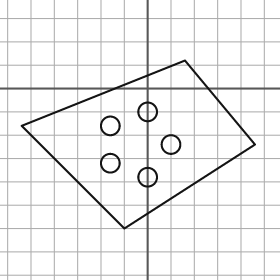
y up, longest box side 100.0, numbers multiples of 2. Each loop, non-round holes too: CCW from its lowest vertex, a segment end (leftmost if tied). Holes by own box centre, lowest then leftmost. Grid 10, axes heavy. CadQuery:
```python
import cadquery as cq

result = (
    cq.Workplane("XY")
    .moveTo(-10.0, -60.0)
    .lineTo(46.0, -24.0)
    .lineTo(16.0, 12.0)
    .lineTo(-54.0, -16.0)
    .close()
    .moveTo(0.0, -38.0)
    .circle(4.0)
    .moveTo(-16.0, -32.0)
    .circle(4.0)
    .moveTo(10.0, -24.0)
    .circle(4.0)
    .moveTo(-16.0, -16.0)
    .circle(4.0)
    .moveTo(0.0, -10.0)
    .circle(4.0)
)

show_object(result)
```